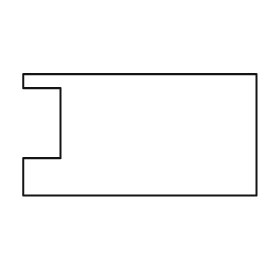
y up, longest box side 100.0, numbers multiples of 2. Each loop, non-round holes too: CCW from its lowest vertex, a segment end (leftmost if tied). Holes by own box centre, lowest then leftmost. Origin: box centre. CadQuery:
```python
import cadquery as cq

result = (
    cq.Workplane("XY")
    .moveTo(-50.0, -26.0)
    .lineTo(50.0, -26.0)
    .lineTo(50.0, 26.0)
    .lineTo(-50.0, 26.0)
    .lineTo(-50.0, 20.0)
    .lineTo(-34.0, 20.0)
    .lineTo(-34.0, -10.0)
    .lineTo(-50.0, -10.0)
    .close()
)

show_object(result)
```